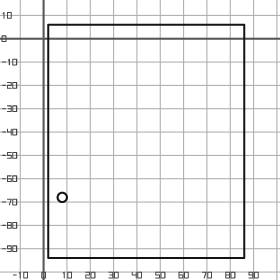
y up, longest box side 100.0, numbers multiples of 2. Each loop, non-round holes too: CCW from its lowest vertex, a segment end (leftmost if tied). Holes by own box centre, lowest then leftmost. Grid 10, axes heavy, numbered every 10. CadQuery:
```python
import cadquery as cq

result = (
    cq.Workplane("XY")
    .moveTo(2.0, -94.0)
    .lineTo(86.0, -94.0)
    .lineTo(86.0, 6.0)
    .lineTo(2.0, 6.0)
    .close()
    .moveTo(8.0, -68.0)
    .circle(2.0)
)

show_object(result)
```